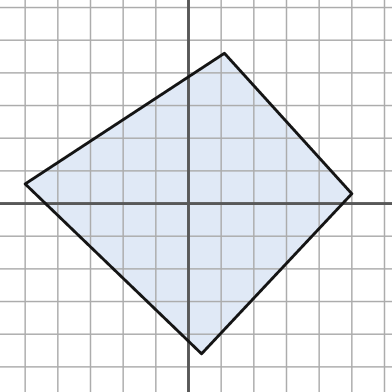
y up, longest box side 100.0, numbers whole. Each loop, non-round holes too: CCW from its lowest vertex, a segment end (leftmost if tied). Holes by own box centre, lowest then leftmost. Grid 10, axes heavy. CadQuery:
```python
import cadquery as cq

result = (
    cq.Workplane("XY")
    .moveTo(4.0, -46.0)
    .lineTo(50.0, 3.0)
    .lineTo(11.0, 46.0)
    .lineTo(-50.0, 6.0)
    .close()
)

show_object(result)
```